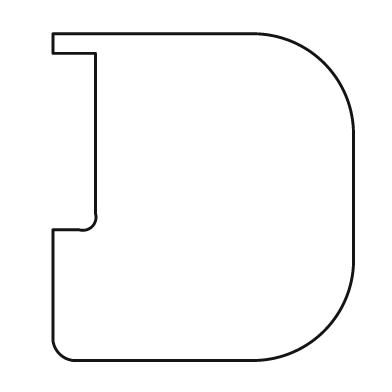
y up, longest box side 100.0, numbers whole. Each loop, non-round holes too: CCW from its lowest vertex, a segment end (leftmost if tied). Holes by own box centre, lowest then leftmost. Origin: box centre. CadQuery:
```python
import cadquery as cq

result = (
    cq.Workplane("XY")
    .moveTo(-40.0, -50.0)
    .lineTo(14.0, -50.0)
    .threePointArc((37.0, -41.0), (46.0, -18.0))
    .lineTo(46.0, 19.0)
    .threePointArc((37.0, 41.0), (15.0, 50.0))
    .lineTo(-46.0, 50.0)
    .lineTo(-46.0, 44.0)
    .lineTo(-33.0, 44.0)
    .lineTo(-33.0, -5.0)
    .threePointArc((-34.0, -9.0), (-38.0, -10.0))
    .lineTo(-46.0, -10.0)
    .lineTo(-46.0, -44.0)
    .threePointArc((-44.0, -48.0), (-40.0, -50.0))
    .close()
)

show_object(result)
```